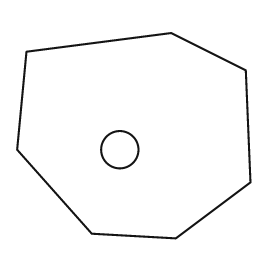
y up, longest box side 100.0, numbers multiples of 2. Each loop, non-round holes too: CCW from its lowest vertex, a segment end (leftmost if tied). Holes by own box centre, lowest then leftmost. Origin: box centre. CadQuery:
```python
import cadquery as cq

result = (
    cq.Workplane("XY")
    .moveTo(18.0, -44.0)
    .lineTo(50.0, -20.0)
    .lineTo(48.0, 28.0)
    .lineTo(16.0, 44.0)
    .lineTo(-46.0, 36.0)
    .lineTo(-50.0, -6.0)
    .lineTo(-18.0, -42.0)
    .close()
    .moveTo(-6.0, -6.0)
    .circle(8.0)
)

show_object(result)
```